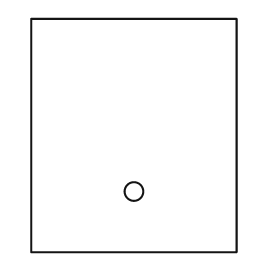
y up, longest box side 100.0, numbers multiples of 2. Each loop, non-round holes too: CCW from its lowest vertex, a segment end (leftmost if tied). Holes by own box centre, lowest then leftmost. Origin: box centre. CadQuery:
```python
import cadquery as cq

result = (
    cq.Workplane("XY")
    .moveTo(-44.0, -50.0)
    .lineTo(44.0, -50.0)
    .lineTo(44.0, 50.0)
    .lineTo(-44.0, 50.0)
    .close()
    .moveTo(0.0, -24.0)
    .circle(4.0)
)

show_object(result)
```